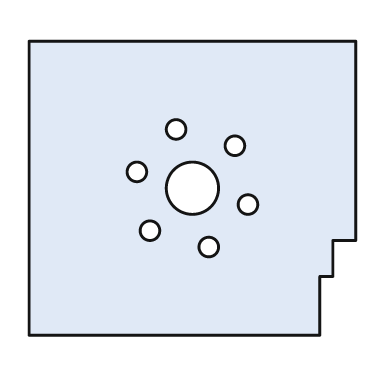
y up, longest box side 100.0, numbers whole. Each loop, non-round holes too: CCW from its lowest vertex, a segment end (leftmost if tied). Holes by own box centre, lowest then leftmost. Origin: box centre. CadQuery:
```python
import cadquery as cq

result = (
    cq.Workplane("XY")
    .moveTo(-50.0, -45.0)
    .lineTo(39.0, -45.0)
    .lineTo(39.0, -27.0)
    .lineTo(43.0, -27.0)
    .lineTo(43.0, -16.0)
    .lineTo(50.0, -16.0)
    .lineTo(50.0, 45.0)
    .lineTo(-50.0, 45.0)
    .close()
    .moveTo(5.0, -18.0)
    .circle(3.0)
    .moveTo(-13.0, -13.0)
    .circle(3.0)
    .moveTo(17.0, -5.0)
    .circle(3.0)
    .moveTo(0.0, 0.0)
    .circle(8.0)
    .moveTo(-17.0, 5.0)
    .circle(3.0)
    .moveTo(13.0, 13.0)
    .circle(3.0)
    .moveTo(-5.0, 18.0)
    .circle(3.0)
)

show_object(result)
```